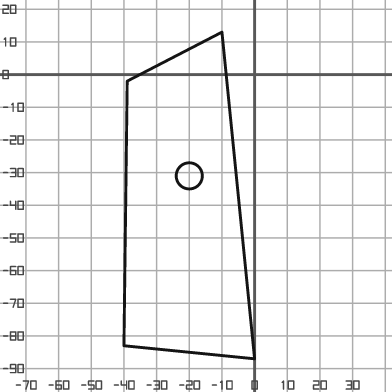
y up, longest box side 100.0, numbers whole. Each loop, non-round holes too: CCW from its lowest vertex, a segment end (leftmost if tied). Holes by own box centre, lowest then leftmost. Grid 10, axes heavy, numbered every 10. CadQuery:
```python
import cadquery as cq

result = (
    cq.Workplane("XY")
    .moveTo(0.0, -87.0)
    .lineTo(-10.0, 13.0)
    .lineTo(-39.0, -2.0)
    .lineTo(-40.0, -83.0)
    .close()
    .moveTo(-20.0, -31.0)
    .circle(4.0)
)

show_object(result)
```